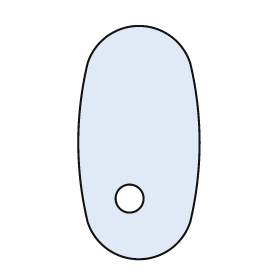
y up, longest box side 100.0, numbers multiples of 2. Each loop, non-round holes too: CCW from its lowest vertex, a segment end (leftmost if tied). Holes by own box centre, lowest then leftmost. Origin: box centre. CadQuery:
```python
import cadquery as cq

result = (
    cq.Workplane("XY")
    .moveTo(-22.0, -34.0)
    .threePointArc((0.0, -50.0), (22.0, -34.0))
    .threePointArc((26.0, 0.0), (22.0, 34.0))
    .threePointArc((0.0, 50.0), (-22.0, 34.0))
    .threePointArc((-26.0, 0.0), (-22.0, -34.0))
    .close()
    .moveTo(-4.0, -24.0)
    .circle(6.0)
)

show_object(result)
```